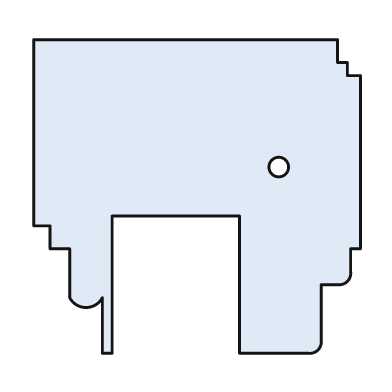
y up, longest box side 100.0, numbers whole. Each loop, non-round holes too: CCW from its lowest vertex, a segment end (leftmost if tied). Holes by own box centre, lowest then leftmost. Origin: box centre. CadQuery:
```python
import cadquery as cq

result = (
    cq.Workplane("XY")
    .moveTo(-29.0, -48.0)
    .lineTo(-26.0, -48.0)
    .lineTo(-26.0, -6.0)
    .lineTo(13.0, -6.0)
    .lineTo(13.0, -48.0)
    .lineTo(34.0, -48.0)
    .threePointArc((37.0, -47.0), (38.0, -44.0))
    .lineTo(38.0, -27.0)
    .lineTo(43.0, -27.0)
    .threePointArc((46.0, -26.0), (47.0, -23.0))
    .lineTo(47.0, -16.0)
    .lineTo(50.0, -16.0)
    .lineTo(50.0, 37.0)
    .lineTo(46.0, 37.0)
    .lineTo(46.0, 41.0)
    .lineTo(43.0, 41.0)
    .lineTo(43.0, 48.0)
    .lineTo(-50.0, 48.0)
    .lineTo(-50.0, -9.0)
    .lineTo(-45.0, -9.0)
    .lineTo(-45.0, -16.0)
    .lineTo(-39.0, -16.0)
    .lineTo(-39.0, -31.0)
    .threePointArc((-34.0, -34.0), (-29.0, -31.0))
    .close()
    .moveTo(25.0, 9.0)
    .circle(3.0)
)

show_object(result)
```